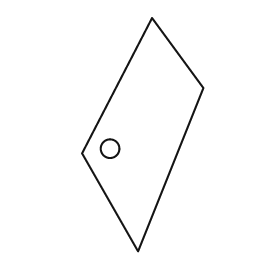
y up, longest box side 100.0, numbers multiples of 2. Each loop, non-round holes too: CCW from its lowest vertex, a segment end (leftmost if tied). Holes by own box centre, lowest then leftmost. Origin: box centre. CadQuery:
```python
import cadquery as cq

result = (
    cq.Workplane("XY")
    .moveTo(-2.0, -50.0)
    .lineTo(26.0, 20.0)
    .lineTo(4.0, 50.0)
    .lineTo(-26.0, -8.0)
    .close()
    .moveTo(-14.0, -6.0)
    .circle(4.0)
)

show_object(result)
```